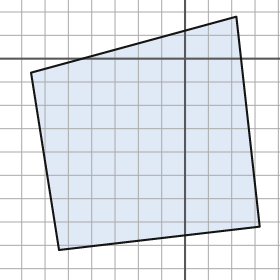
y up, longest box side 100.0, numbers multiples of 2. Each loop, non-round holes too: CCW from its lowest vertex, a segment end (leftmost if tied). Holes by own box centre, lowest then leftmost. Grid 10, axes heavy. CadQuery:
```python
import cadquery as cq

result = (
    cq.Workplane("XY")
    .moveTo(-54.0, -82.0)
    .lineTo(32.0, -72.0)
    .lineTo(22.0, 18.0)
    .lineTo(-66.0, -6.0)
    .close()
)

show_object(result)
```